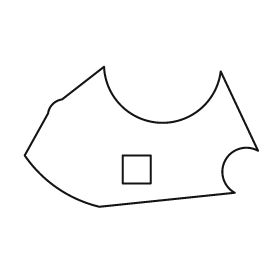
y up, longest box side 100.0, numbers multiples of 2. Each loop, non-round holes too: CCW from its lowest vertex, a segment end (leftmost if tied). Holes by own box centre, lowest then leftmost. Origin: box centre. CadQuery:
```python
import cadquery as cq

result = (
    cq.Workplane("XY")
    .moveTo(-18.0, -30.0)
    .lineTo(40.0, -24.0)
    .threePointArc((36.0, -10.0), (50.0, -6.0))
    .lineTo(34.0, 28.0)
    .threePointArc((8.0, 6.0), (-16.0, 30.0))
    .lineTo(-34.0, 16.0)
    .threePointArc((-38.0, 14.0), (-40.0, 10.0))
    .lineTo(-50.0, -8.0)
    .threePointArc((-36.0, -22.0), (-18.0, -30.0))
    .close()
    .moveTo(-8.0, -20.0)
    .lineTo(4.0, -20.0)
    .lineTo(4.0, -8.0)
    .lineTo(-8.0, -8.0)
    .close()
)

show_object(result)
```